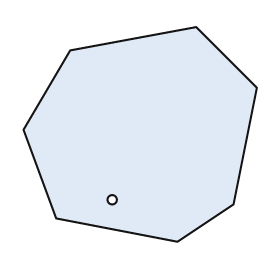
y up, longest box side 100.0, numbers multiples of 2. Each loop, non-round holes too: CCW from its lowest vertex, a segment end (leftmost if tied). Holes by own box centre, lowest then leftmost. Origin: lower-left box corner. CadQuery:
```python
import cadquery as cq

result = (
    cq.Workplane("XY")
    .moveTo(66.0, 0.0)
    .lineTo(90.0, 16.0)
    .lineTo(100.0, 66.0)
    .lineTo(74.0, 92.0)
    .lineTo(20.0, 82.0)
    .lineTo(0.0, 48.0)
    .lineTo(14.0, 10.0)
    .close()
    .moveTo(38.0, 18.0)
    .circle(2.0)
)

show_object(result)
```